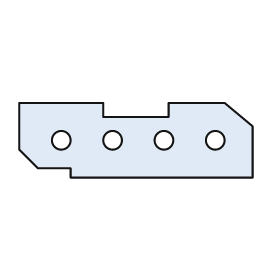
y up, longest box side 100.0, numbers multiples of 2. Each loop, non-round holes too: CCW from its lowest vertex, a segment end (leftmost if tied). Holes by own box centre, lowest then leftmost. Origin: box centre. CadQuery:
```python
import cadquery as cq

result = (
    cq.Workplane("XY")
    .moveTo(-28.0, -16.0)
    .lineTo(50.0, -16.0)
    .lineTo(50.0, 6.0)
    .lineTo(38.0, 16.0)
    .lineTo(14.0, 16.0)
    .lineTo(14.0, 10.0)
    .lineTo(-14.0, 10.0)
    .lineTo(-14.0, 16.0)
    .lineTo(-50.0, 16.0)
    .lineTo(-50.0, -4.0)
    .lineTo(-42.0, -12.0)
    .lineTo(-28.0, -12.0)
    .close()
    .moveTo(-32.0, 0.0)
    .circle(4.0)
    .moveTo(-10.0, 0.0)
    .circle(4.0)
    .moveTo(12.0, 0.0)
    .circle(4.0)
    .moveTo(34.0, 0.0)
    .circle(4.0)
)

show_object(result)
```